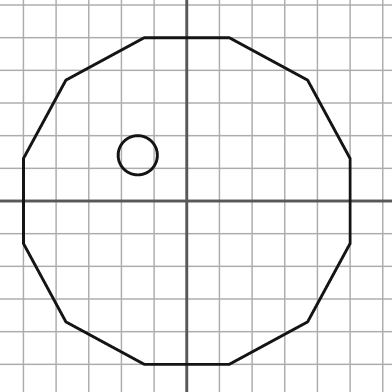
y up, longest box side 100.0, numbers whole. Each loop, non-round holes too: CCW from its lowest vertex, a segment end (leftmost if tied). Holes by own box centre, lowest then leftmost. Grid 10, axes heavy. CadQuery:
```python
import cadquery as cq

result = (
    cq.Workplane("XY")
    .moveTo(-13.0, -50.0)
    .lineTo(13.0, -50.0)
    .lineTo(37.0, -37.0)
    .lineTo(50.0, -13.0)
    .lineTo(50.0, 13.0)
    .lineTo(37.0, 37.0)
    .lineTo(13.0, 50.0)
    .lineTo(-13.0, 50.0)
    .lineTo(-37.0, 37.0)
    .lineTo(-50.0, 13.0)
    .lineTo(-50.0, -13.0)
    .lineTo(-37.0, -37.0)
    .close()
    .moveTo(-15.0, 14.0)
    .circle(6.0)
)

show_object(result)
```